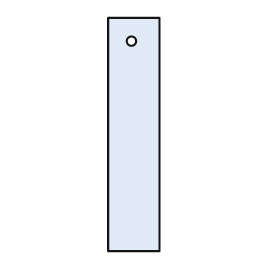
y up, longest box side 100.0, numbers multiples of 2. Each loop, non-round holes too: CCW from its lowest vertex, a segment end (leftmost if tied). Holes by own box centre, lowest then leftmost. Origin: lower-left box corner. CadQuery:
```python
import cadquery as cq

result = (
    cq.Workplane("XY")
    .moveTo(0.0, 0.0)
    .lineTo(22.0, 0.0)
    .lineTo(22.0, 100.0)
    .lineTo(0.0, 100.0)
    .close()
    .moveTo(10.0, 90.0)
    .circle(2.0)
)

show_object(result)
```